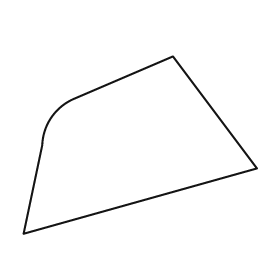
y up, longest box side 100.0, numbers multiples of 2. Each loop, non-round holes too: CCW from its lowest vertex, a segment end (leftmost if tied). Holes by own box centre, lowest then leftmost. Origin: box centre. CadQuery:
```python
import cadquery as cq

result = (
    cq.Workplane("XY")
    .moveTo(-50.0, -38.0)
    .lineTo(50.0, -10.0)
    .lineTo(14.0, 38.0)
    .lineTo(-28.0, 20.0)
    .threePointArc((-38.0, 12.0), (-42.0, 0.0))
    .close()
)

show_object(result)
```